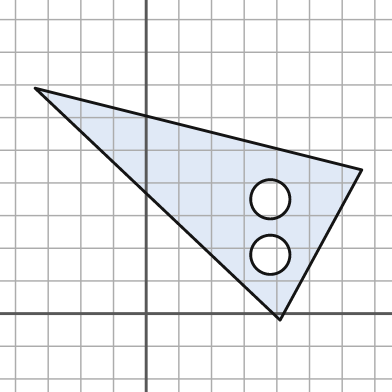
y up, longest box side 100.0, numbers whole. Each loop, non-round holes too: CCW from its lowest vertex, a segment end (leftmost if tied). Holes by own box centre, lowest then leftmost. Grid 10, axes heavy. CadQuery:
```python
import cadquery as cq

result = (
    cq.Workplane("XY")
    .moveTo(41.0, -2.0)
    .lineTo(66.0, 44.0)
    .lineTo(-34.0, 69.0)
    .close()
    .moveTo(38.0, 18.0)
    .circle(6.0)
    .moveTo(38.0, 35.0)
    .circle(6.0)
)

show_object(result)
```